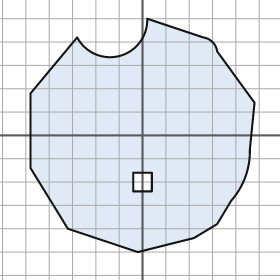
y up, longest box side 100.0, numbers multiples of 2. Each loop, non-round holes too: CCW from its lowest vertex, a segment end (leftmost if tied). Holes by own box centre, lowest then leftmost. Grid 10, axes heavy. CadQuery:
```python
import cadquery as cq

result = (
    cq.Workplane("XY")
    .moveTo(-2.0, -50.0)
    .lineTo(22.0, -44.0)
    .lineTo(32.0, -38.0)
    .lineTo(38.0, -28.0)
    .threePointArc((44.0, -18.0), (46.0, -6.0))
    .lineTo(48.0, 14.0)
    .lineTo(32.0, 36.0)
    .threePointArc((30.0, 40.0), (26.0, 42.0))
    .lineTo(2.0, 50.0)
    .threePointArc((-10.0, 34.0), (-28.0, 42.0))
    .lineTo(-48.0, 18.0)
    .lineTo(-48.0, -14.0)
    .lineTo(-32.0, -40.0)
    .close()
    .moveTo(-4.0, -24.0)
    .lineTo(4.0, -24.0)
    .lineTo(4.0, -16.0)
    .lineTo(-4.0, -16.0)
    .close()
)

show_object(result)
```